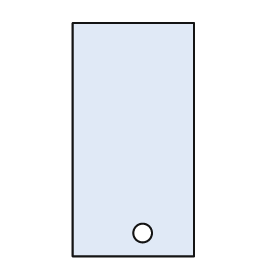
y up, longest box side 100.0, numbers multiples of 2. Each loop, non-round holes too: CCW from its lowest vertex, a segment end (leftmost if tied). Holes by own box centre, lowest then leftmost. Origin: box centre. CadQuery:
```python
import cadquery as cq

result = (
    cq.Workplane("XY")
    .moveTo(-26.0, -50.0)
    .lineTo(26.0, -50.0)
    .lineTo(26.0, 50.0)
    .lineTo(-26.0, 50.0)
    .close()
    .moveTo(4.0, -40.0)
    .circle(4.0)
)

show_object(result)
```